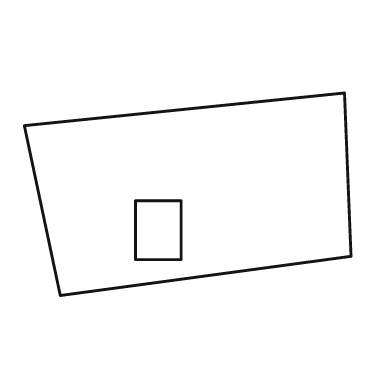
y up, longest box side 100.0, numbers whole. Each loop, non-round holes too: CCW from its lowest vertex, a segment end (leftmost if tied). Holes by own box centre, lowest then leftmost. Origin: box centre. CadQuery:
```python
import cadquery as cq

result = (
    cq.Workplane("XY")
    .moveTo(-39.0, -31.0)
    .lineTo(50.0, -19.0)
    .lineTo(48.0, 31.0)
    .lineTo(-50.0, 21.0)
    .close()
    .moveTo(-16.0, -20.0)
    .lineTo(-2.0, -20.0)
    .lineTo(-2.0, -2.0)
    .lineTo(-16.0, -2.0)
    .close()
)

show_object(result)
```